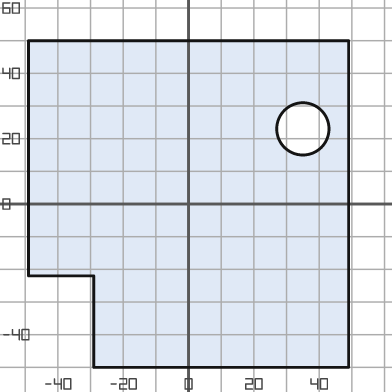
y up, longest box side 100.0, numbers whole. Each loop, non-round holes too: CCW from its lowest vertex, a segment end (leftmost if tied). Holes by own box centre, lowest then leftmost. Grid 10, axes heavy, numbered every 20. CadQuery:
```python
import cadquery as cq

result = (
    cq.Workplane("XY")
    .moveTo(-29.0, -50.0)
    .lineTo(49.0, -50.0)
    .lineTo(49.0, 50.0)
    .lineTo(-49.0, 50.0)
    .lineTo(-49.0, -22.0)
    .lineTo(-29.0, -22.0)
    .close()
    .moveTo(35.0, 23.0)
    .circle(8.0)
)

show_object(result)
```